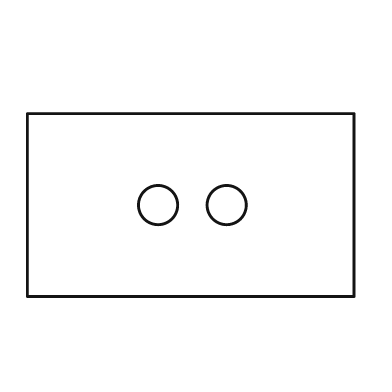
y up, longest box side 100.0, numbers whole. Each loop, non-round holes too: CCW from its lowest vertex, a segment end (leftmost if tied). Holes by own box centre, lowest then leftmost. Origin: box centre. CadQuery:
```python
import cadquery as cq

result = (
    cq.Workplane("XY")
    .moveTo(-50.0, -28.0)
    .lineTo(50.0, -28.0)
    .lineTo(50.0, 28.0)
    .lineTo(-50.0, 28.0)
    .close()
    .moveTo(-10.0, 0.0)
    .circle(6.0)
    .moveTo(11.0, 0.0)
    .circle(6.0)
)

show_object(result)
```